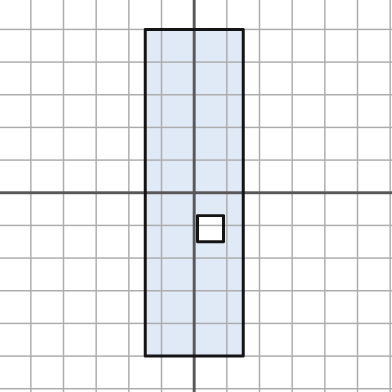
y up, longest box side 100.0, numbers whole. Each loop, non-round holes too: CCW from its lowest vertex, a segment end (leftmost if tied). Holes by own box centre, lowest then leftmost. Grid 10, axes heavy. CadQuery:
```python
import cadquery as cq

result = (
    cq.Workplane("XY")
    .moveTo(-15.0, -50.0)
    .lineTo(15.0, -50.0)
    .lineTo(15.0, 50.0)
    .lineTo(-15.0, 50.0)
    .close()
    .moveTo(1.0, -15.0)
    .lineTo(9.0, -15.0)
    .lineTo(9.0, -7.0)
    .lineTo(1.0, -7.0)
    .close()
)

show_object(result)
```